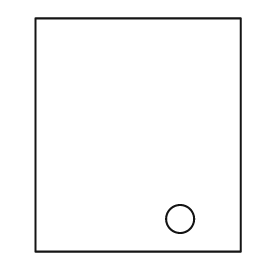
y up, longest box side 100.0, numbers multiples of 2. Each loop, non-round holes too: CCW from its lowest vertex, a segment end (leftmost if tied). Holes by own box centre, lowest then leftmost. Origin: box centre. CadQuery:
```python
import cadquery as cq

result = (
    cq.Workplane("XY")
    .moveTo(-44.0, -50.0)
    .lineTo(44.0, -50.0)
    .lineTo(44.0, 50.0)
    .lineTo(-44.0, 50.0)
    .close()
    .moveTo(18.0, -36.0)
    .circle(6.0)
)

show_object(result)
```